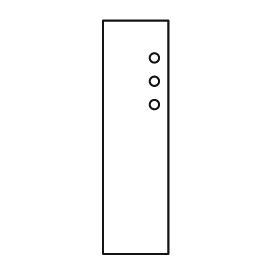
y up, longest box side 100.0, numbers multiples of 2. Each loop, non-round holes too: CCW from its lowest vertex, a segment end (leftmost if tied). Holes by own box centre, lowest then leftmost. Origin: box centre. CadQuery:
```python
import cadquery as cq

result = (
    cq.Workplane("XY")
    .moveTo(-14.0, -50.0)
    .lineTo(14.0, -50.0)
    .lineTo(14.0, 50.0)
    .lineTo(-14.0, 50.0)
    .close()
    .moveTo(8.0, 14.0)
    .circle(2.0)
    .moveTo(8.0, 24.0)
    .circle(2.0)
    .moveTo(8.0, 34.0)
    .circle(2.0)
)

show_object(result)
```